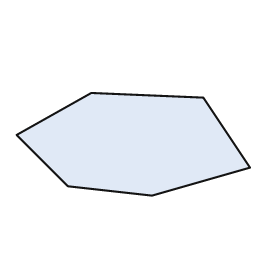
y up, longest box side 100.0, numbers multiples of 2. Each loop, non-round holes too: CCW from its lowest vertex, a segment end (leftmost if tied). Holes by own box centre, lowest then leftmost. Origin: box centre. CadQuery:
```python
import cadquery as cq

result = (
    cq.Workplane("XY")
    .moveTo(8.0, -22.0)
    .lineTo(50.0, -10.0)
    .lineTo(30.0, 20.0)
    .lineTo(-18.0, 22.0)
    .lineTo(-50.0, 4.0)
    .lineTo(-28.0, -18.0)
    .close()
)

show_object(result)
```